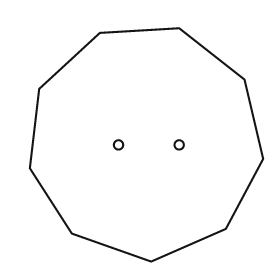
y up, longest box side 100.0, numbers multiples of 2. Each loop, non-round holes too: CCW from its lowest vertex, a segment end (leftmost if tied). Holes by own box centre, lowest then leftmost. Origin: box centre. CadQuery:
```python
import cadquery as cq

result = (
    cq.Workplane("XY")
    .moveTo(2.0, -50.0)
    .lineTo(34.0, -36.0)
    .lineTo(50.0, -6.0)
    .lineTo(42.0, 28.0)
    .lineTo(14.0, 50.0)
    .lineTo(-20.0, 48.0)
    .lineTo(-46.0, 24.0)
    .lineTo(-50.0, -10.0)
    .lineTo(-32.0, -38.0)
    .close()
    .moveTo(-12.0, 0.0)
    .circle(2.0)
    .moveTo(14.0, 0.0)
    .circle(2.0)
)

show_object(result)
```